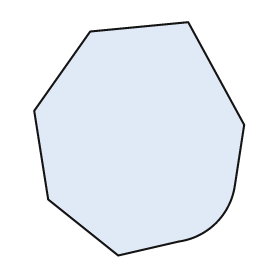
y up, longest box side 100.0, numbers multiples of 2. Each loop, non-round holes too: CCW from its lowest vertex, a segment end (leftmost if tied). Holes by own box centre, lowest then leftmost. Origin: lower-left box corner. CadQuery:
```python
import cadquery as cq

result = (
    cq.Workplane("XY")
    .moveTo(36.0, 0.0)
    .lineTo(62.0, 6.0)
    .threePointArc((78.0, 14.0), (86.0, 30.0))
    .lineTo(90.0, 56.0)
    .lineTo(66.0, 100.0)
    .lineTo(24.0, 96.0)
    .lineTo(0.0, 62.0)
    .lineTo(6.0, 24.0)
    .close()
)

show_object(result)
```